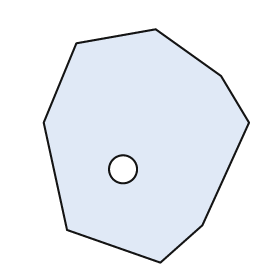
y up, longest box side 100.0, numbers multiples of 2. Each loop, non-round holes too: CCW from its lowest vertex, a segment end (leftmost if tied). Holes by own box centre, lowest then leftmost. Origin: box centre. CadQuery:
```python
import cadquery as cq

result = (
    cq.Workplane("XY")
    .moveTo(6.0, -50.0)
    .lineTo(24.0, -34.0)
    .lineTo(44.0, 10.0)
    .lineTo(32.0, 30.0)
    .lineTo(4.0, 50.0)
    .lineTo(-30.0, 44.0)
    .lineTo(-44.0, 10.0)
    .lineTo(-34.0, -36.0)
    .close()
    .moveTo(-10.0, -10.0)
    .circle(6.0)
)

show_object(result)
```